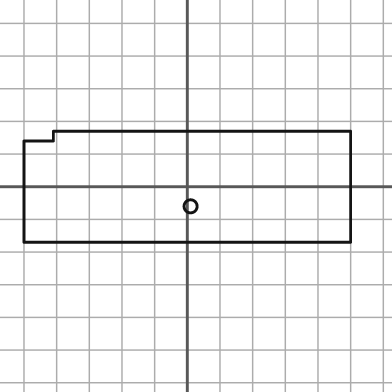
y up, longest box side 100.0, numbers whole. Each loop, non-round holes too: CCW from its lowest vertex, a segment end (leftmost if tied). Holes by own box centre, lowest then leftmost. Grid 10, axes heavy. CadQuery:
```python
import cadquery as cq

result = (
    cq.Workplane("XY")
    .moveTo(-50.0, -17.0)
    .lineTo(50.0, -17.0)
    .lineTo(50.0, 17.0)
    .lineTo(-41.0, 17.0)
    .lineTo(-41.0, 14.0)
    .lineTo(-50.0, 14.0)
    .close()
    .moveTo(1.0, -6.0)
    .circle(2.0)
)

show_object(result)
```